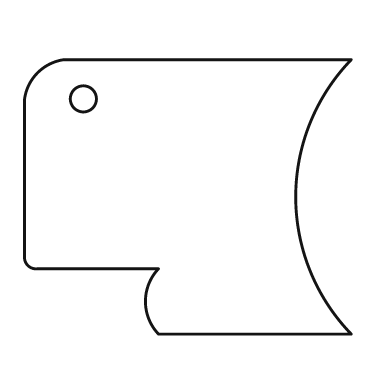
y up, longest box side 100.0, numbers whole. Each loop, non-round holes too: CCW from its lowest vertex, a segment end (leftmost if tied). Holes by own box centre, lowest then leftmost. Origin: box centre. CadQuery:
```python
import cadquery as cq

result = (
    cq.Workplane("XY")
    .moveTo(-9.0, -42.0)
    .lineTo(50.0, -42.0)
    .threePointArc((33.0, 0.0), (50.0, 42.0))
    .lineTo(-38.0, 42.0)
    .threePointArc((-46.0, 38.0), (-50.0, 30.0))
    .lineTo(-50.0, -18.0)
    .threePointArc((-49.0, -21.0), (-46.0, -22.0))
    .lineTo(-9.0, -22.0)
    .threePointArc((-13.0, -32.0), (-9.0, -42.0))
    .close()
    .moveTo(-32.0, 30.0)
    .circle(4.0)
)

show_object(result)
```